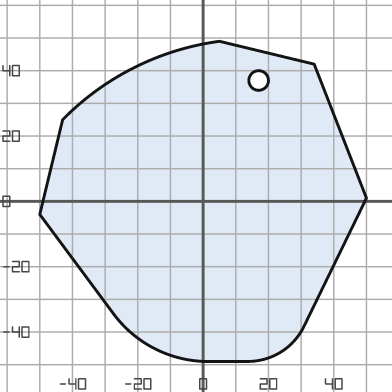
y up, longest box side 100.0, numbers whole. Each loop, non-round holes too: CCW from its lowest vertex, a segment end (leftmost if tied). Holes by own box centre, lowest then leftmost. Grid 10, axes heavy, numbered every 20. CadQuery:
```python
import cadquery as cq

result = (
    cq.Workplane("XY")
    .moveTo(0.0, -49.0)
    .lineTo(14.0, -49.0)
    .threePointArc((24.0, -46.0), (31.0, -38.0))
    .lineTo(50.0, 1.0)
    .lineTo(34.0, 42.0)
    .lineTo(5.0, 49.0)
    .threePointArc((-21.0, 41.0), (-43.0, 25.0))
    .lineTo(-50.0, -4.0)
    .lineTo(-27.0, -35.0)
    .threePointArc((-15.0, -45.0), (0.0, -49.0))
    .close()
    .moveTo(17.0, 37.0)
    .circle(3.0)
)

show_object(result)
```